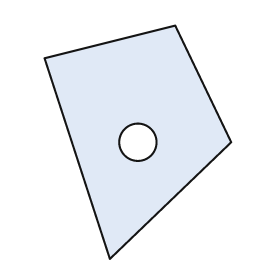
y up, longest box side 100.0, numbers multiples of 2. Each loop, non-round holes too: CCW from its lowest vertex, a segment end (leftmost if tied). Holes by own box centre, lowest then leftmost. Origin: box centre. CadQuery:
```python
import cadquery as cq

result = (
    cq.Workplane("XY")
    .moveTo(-12.0, -50.0)
    .lineTo(40.0, 0.0)
    .lineTo(16.0, 50.0)
    .lineTo(-40.0, 36.0)
    .close()
    .moveTo(0.0, 0.0)
    .circle(8.0)
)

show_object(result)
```